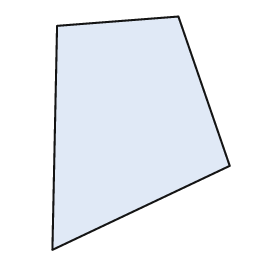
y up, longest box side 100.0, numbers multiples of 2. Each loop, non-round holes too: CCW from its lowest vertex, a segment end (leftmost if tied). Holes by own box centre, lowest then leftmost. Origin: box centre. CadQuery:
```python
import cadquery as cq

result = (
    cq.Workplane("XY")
    .moveTo(-38.0, -50.0)
    .lineTo(38.0, -14.0)
    .lineTo(16.0, 50.0)
    .lineTo(-36.0, 46.0)
    .close()
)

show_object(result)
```